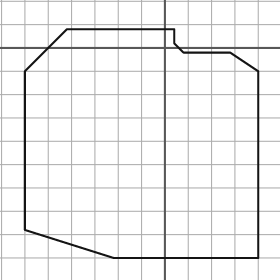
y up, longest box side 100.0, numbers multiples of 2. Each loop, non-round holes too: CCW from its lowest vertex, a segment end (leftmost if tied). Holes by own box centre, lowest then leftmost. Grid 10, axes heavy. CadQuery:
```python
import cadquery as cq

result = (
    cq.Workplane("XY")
    .moveTo(-22.0, -90.0)
    .lineTo(40.0, -90.0)
    .lineTo(40.0, -10.0)
    .lineTo(28.0, -2.0)
    .lineTo(8.0, -2.0)
    .lineTo(4.0, 2.0)
    .lineTo(4.0, 8.0)
    .lineTo(-42.0, 8.0)
    .lineTo(-60.0, -10.0)
    .lineTo(-60.0, -78.0)
    .close()
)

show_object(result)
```